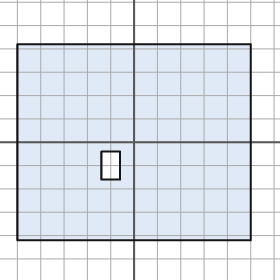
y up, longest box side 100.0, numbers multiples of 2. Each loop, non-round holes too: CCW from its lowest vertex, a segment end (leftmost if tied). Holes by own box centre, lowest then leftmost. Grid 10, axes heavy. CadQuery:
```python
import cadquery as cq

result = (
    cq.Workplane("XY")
    .moveTo(-50.0, -42.0)
    .lineTo(50.0, -42.0)
    .lineTo(50.0, 42.0)
    .lineTo(-50.0, 42.0)
    .close()
    .moveTo(-14.0, -16.0)
    .lineTo(-6.0, -16.0)
    .lineTo(-6.0, -4.0)
    .lineTo(-14.0, -4.0)
    .close()
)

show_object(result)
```